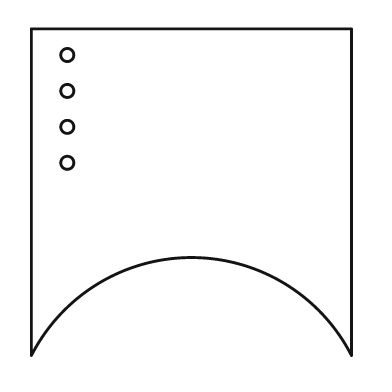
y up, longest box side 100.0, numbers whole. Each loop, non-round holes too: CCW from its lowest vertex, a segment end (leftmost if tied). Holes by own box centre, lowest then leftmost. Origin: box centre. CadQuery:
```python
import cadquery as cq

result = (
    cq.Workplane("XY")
    .moveTo(-49.0, -50.0)
    .threePointArc((0.0, -20.0), (49.0, -50.0))
    .lineTo(49.0, 50.0)
    .lineTo(-49.0, 50.0)
    .close()
    .moveTo(-38.0, 9.0)
    .circle(2.0)
    .moveTo(-38.0, 20.0)
    .circle(2.0)
    .moveTo(-38.0, 31.0)
    .circle(2.0)
    .moveTo(-38.0, 42.0)
    .circle(2.0)
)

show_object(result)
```